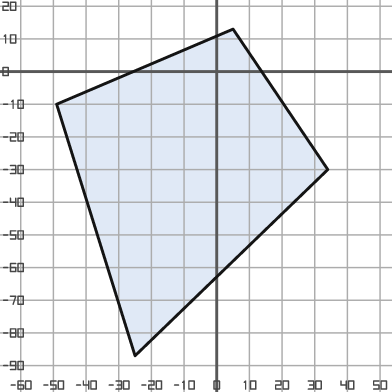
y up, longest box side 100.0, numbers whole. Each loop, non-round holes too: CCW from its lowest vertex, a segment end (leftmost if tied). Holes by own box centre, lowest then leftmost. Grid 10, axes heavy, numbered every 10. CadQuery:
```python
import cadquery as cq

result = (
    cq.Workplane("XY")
    .moveTo(-25.0, -87.0)
    .lineTo(34.0, -30.0)
    .lineTo(5.0, 13.0)
    .lineTo(-49.0, -10.0)
    .close()
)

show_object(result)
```